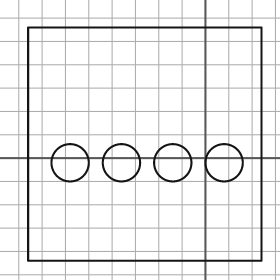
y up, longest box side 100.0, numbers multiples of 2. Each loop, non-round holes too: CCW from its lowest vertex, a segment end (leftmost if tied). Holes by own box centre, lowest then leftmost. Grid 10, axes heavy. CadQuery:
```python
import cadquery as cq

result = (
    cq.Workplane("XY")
    .moveTo(-76.0, -44.0)
    .lineTo(24.0, -44.0)
    .lineTo(24.0, 56.0)
    .lineTo(-76.0, 56.0)
    .close()
    .moveTo(-58.0, -2.0)
    .circle(8.0)
    .moveTo(-36.0, -2.0)
    .circle(8.0)
    .moveTo(-14.0, -2.0)
    .circle(8.0)
    .moveTo(8.0, -2.0)
    .circle(8.0)
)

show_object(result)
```